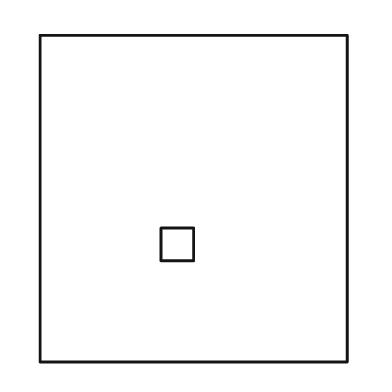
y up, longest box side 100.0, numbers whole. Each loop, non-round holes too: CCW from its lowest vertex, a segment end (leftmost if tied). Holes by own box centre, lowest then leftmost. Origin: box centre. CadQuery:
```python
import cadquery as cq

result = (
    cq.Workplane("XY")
    .moveTo(-47.0, -50.0)
    .lineTo(47.0, -50.0)
    .lineTo(47.0, 50.0)
    .lineTo(-47.0, 50.0)
    .close()
    .moveTo(-10.0, -19.0)
    .lineTo(0.0, -19.0)
    .lineTo(0.0, -9.0)
    .lineTo(-10.0, -9.0)
    .close()
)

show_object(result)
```